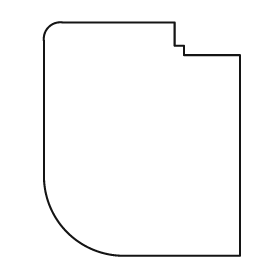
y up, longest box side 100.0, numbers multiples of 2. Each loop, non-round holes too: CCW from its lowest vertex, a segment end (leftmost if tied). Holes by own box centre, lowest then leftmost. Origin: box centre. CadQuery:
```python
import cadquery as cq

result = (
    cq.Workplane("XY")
    .moveTo(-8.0, -50.0)
    .lineTo(42.0, -50.0)
    .lineTo(42.0, 36.0)
    .lineTo(18.0, 36.0)
    .lineTo(18.0, 40.0)
    .lineTo(14.0, 40.0)
    .lineTo(14.0, 50.0)
    .lineTo(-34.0, 50.0)
    .threePointArc((-40.0, 48.0), (-42.0, 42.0))
    .lineTo(-42.0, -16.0)
    .threePointArc((-32.0, -40.0), (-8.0, -50.0))
    .close()
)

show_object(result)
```